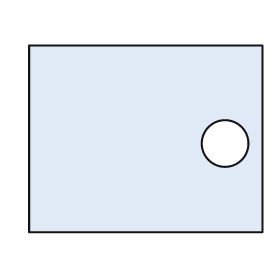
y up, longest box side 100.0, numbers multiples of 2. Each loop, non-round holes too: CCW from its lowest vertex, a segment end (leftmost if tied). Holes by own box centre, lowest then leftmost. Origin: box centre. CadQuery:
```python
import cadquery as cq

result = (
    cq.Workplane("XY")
    .moveTo(-50.0, -40.0)
    .lineTo(50.0, -40.0)
    .lineTo(50.0, 40.0)
    .lineTo(-50.0, 40.0)
    .close()
    .moveTo(34.0, -2.0)
    .circle(10.0)
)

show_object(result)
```